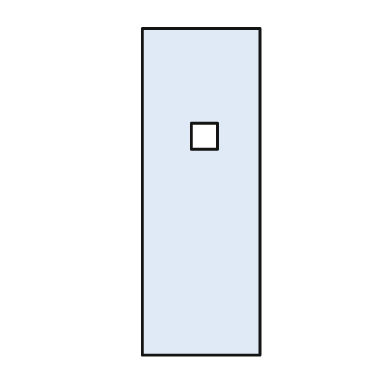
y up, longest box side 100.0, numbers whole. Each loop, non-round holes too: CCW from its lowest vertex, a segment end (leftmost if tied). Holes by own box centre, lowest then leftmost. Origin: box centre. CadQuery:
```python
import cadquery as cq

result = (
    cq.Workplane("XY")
    .moveTo(-18.0, -50.0)
    .lineTo(18.0, -50.0)
    .lineTo(18.0, 50.0)
    .lineTo(-18.0, 50.0)
    .close()
    .moveTo(-3.0, 13.0)
    .lineTo(5.0, 13.0)
    .lineTo(5.0, 21.0)
    .lineTo(-3.0, 21.0)
    .close()
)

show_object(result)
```